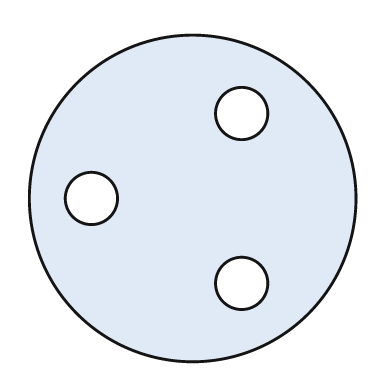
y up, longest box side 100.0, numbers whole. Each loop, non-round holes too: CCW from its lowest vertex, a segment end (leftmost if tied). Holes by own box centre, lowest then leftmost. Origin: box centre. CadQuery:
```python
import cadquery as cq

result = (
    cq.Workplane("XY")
    .moveTo(0.0, 0.0)
    .circle(50.0)
    .moveTo(15.0, -26.0)
    .circle(8.0)
    .moveTo(-31.0, 0.0)
    .circle(8.0)
    .moveTo(15.0, 26.0)
    .circle(8.0)
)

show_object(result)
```